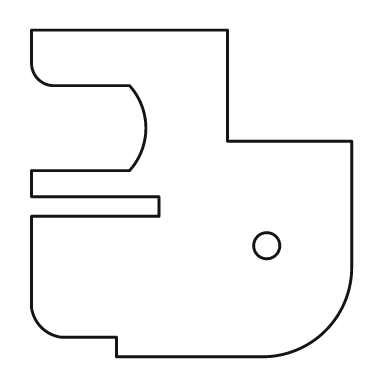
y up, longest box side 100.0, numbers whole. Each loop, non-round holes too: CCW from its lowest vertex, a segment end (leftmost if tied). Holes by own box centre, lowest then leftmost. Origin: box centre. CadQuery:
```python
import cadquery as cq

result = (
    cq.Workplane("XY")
    .moveTo(-23.0, -50.0)
    .lineTo(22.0, -50.0)
    .threePointArc((41.0, -42.0), (49.0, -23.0))
    .lineTo(49.0, 16.0)
    .lineTo(11.0, 16.0)
    .lineTo(11.0, 50.0)
    .lineTo(-49.0, 50.0)
    .lineTo(-49.0, 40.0)
    .threePointArc((-47.0, 35.0), (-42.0, 33.0))
    .lineTo(-19.0, 33.0)
    .threePointArc((-14.0, 20.0), (-19.0, 7.0))
    .lineTo(-49.0, 7.0)
    .lineTo(-49.0, -1.0)
    .lineTo(-10.0, -1.0)
    .lineTo(-10.0, -7.0)
    .lineTo(-49.0, -7.0)
    .lineTo(-49.0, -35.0)
    .threePointArc((-46.0, -41.0), (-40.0, -44.0))
    .lineTo(-23.0, -44.0)
    .close()
    .moveTo(23.0, -16.0)
    .circle(4.0)
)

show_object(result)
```